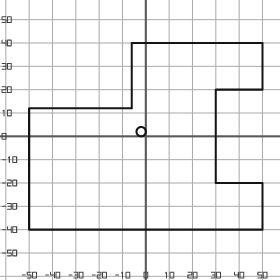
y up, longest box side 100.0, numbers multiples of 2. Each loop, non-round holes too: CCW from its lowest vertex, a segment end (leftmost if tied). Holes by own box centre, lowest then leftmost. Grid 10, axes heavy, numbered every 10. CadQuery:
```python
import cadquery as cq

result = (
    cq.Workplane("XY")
    .moveTo(-50.0, -40.0)
    .lineTo(50.0, -40.0)
    .lineTo(50.0, -20.0)
    .lineTo(30.0, -20.0)
    .lineTo(30.0, 20.0)
    .lineTo(50.0, 20.0)
    .lineTo(50.0, 40.0)
    .lineTo(-6.0, 40.0)
    .lineTo(-6.0, 12.0)
    .lineTo(-50.0, 12.0)
    .close()
    .moveTo(-2.0, 2.0)
    .circle(2.0)
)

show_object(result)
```